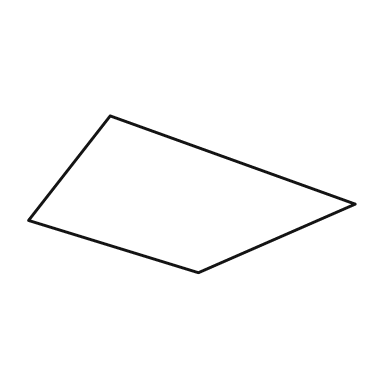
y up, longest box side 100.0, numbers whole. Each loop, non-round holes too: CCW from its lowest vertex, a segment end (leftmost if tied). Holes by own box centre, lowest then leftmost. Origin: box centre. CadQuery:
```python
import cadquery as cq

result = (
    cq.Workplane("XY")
    .moveTo(2.0, -24.0)
    .lineTo(50.0, -3.0)
    .lineTo(-25.0, 24.0)
    .lineTo(-50.0, -8.0)
    .close()
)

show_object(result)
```